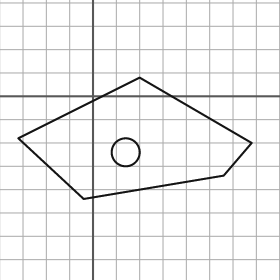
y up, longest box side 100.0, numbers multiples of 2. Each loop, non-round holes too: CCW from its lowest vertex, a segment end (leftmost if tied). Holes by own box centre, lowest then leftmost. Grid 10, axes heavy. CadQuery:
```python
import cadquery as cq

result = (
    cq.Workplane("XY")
    .moveTo(-4.0, -44.0)
    .lineTo(56.0, -34.0)
    .lineTo(68.0, -20.0)
    .lineTo(20.0, 8.0)
    .lineTo(-32.0, -18.0)
    .close()
    .moveTo(14.0, -24.0)
    .circle(6.0)
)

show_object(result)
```